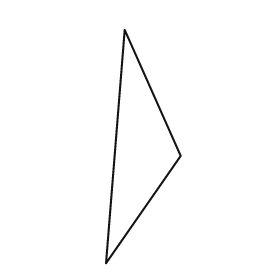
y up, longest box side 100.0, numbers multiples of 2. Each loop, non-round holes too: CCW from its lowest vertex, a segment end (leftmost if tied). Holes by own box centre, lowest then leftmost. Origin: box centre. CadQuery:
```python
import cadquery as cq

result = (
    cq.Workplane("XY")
    .moveTo(-16.0, -50.0)
    .lineTo(16.0, -4.0)
    .lineTo(-8.0, 50.0)
    .close()
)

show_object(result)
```